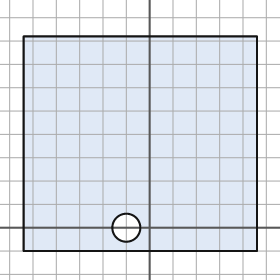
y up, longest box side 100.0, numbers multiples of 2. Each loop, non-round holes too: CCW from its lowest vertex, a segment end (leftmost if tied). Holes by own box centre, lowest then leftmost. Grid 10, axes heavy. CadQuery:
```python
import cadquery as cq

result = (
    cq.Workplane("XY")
    .moveTo(-54.0, -10.0)
    .lineTo(46.0, -10.0)
    .lineTo(46.0, 82.0)
    .lineTo(-54.0, 82.0)
    .close()
    .moveTo(-10.0, 0.0)
    .circle(6.0)
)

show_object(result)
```